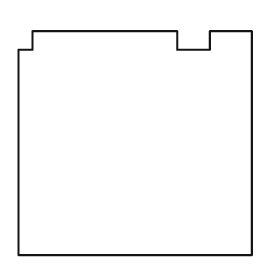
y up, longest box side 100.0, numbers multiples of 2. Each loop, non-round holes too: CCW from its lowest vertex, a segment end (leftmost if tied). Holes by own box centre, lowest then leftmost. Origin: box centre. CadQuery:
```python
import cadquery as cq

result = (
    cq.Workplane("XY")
    .moveTo(-50.0, -48.0)
    .lineTo(50.0, -48.0)
    .lineTo(50.0, 48.0)
    .lineTo(32.0, 48.0)
    .lineTo(32.0, 40.0)
    .lineTo(18.0, 40.0)
    .lineTo(18.0, 48.0)
    .lineTo(-44.0, 48.0)
    .lineTo(-44.0, 40.0)
    .lineTo(-50.0, 40.0)
    .close()
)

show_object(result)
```